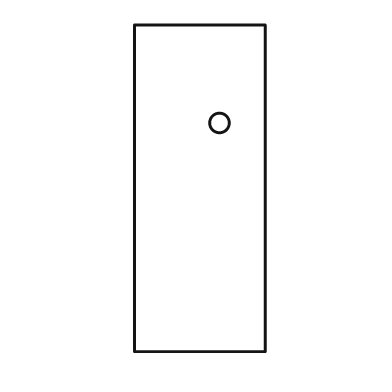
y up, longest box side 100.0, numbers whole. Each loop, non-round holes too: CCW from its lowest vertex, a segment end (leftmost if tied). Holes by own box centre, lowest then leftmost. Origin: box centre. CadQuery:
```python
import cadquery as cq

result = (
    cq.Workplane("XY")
    .moveTo(-20.0, -50.0)
    .lineTo(20.0, -50.0)
    .lineTo(20.0, 50.0)
    .lineTo(-20.0, 50.0)
    .close()
    .moveTo(6.0, 20.0)
    .circle(3.0)
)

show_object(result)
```